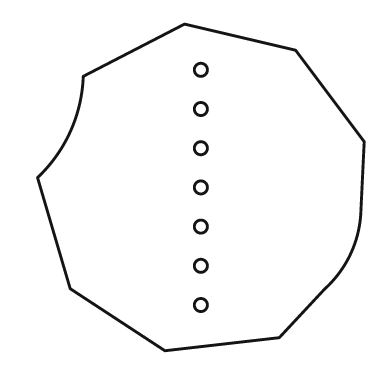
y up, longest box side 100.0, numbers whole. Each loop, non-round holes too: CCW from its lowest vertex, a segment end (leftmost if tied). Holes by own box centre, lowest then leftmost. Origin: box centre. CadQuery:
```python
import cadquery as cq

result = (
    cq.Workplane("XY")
    .moveTo(-11.0, -50.0)
    .lineTo(24.0, -46.0)
    .lineTo(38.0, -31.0)
    .threePointArc((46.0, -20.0), (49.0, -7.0))
    .lineTo(50.0, 14.0)
    .lineTo(29.0, 42.0)
    .lineTo(-5.0, 50.0)
    .lineTo(-36.0, 34.0)
    .threePointArc((-40.0, 17.0), (-50.0, 3.0))
    .lineTo(-40.0, -31.0)
    .close()
    .moveTo(0.0, -36.0)
    .circle(2.0)
    .moveTo(0.0, -24.0)
    .circle(2.0)
    .moveTo(0.0, -12.0)
    .circle(2.0)
    .moveTo(0.0, 0.0)
    .circle(2.0)
    .moveTo(0.0, 12.0)
    .circle(2.0)
    .moveTo(0.0, 24.0)
    .circle(2.0)
    .moveTo(0.0, 36.0)
    .circle(2.0)
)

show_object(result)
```